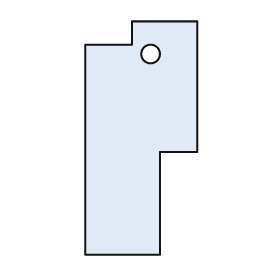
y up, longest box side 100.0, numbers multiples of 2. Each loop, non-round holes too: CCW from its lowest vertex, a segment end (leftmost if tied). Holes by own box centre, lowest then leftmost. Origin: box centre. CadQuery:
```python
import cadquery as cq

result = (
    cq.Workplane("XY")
    .moveTo(-24.0, -50.0)
    .lineTo(8.0, -50.0)
    .lineTo(8.0, -6.0)
    .lineTo(24.0, -6.0)
    .lineTo(24.0, 50.0)
    .lineTo(-4.0, 50.0)
    .lineTo(-4.0, 40.0)
    .lineTo(-24.0, 40.0)
    .close()
    .moveTo(4.0, 36.0)
    .circle(4.0)
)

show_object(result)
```